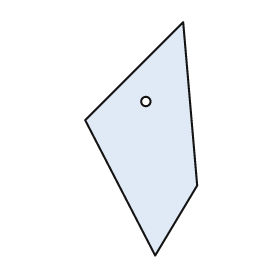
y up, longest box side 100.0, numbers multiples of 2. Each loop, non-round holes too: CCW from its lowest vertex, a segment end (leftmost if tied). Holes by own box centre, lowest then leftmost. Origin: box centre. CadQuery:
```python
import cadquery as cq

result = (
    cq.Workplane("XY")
    .moveTo(6.0, -50.0)
    .lineTo(24.0, -20.0)
    .lineTo(18.0, 50.0)
    .lineTo(-24.0, 8.0)
    .close()
    .moveTo(2.0, 16.0)
    .circle(2.0)
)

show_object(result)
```